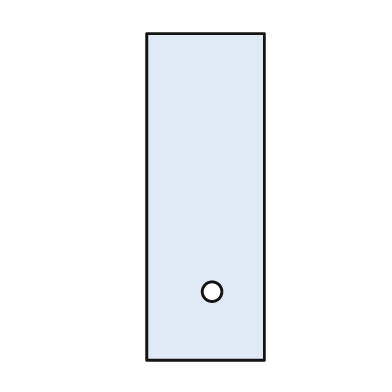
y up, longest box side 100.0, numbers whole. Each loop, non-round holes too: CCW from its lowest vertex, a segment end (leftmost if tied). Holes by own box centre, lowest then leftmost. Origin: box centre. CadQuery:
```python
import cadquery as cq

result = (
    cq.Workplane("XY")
    .moveTo(-18.0, -50.0)
    .lineTo(18.0, -50.0)
    .lineTo(18.0, 50.0)
    .lineTo(-18.0, 50.0)
    .close()
    .moveTo(2.0, -29.0)
    .circle(3.0)
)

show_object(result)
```